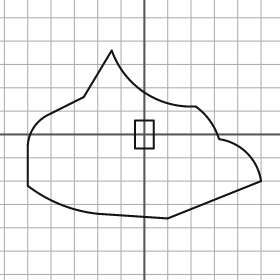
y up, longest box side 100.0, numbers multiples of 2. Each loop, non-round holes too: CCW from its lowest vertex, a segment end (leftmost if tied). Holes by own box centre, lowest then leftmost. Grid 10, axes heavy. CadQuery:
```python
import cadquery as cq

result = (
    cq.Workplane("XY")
    .moveTo(10.0, -36.0)
    .lineTo(50.0, -20.0)
    .threePointArc((44.0, -8.0), (32.0, -2.0))
    .threePointArc((28.0, 6.0), (22.0, 12.0))
    .threePointArc((0.0, 18.0), (-14.0, 36.0))
    .lineTo(-26.0, 16.0)
    .lineTo(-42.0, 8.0)
    .threePointArc((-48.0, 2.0), (-50.0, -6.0))
    .lineTo(-50.0, -22.0)
    .threePointArc((-36.0, -30.0), (-20.0, -34.0))
    .close()
    .moveTo(-4.0, -6.0)
    .lineTo(4.0, -6.0)
    .lineTo(4.0, 6.0)
    .lineTo(-4.0, 6.0)
    .close()
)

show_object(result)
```